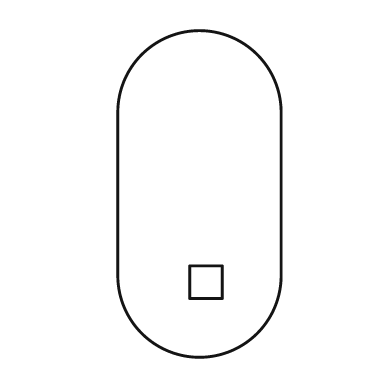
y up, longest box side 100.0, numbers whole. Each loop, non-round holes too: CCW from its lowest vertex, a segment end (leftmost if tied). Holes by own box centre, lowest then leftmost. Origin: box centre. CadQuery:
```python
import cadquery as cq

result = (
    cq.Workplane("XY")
    .moveTo(-25.0, -25.0)
    .threePointArc((0.0, -50.0), (25.0, -25.0))
    .lineTo(25.0, 25.0)
    .threePointArc((0.0, 50.0), (-25.0, 25.0))
    .close()
    .moveTo(-3.0, -32.0)
    .lineTo(7.0, -32.0)
    .lineTo(7.0, -22.0)
    .lineTo(-3.0, -22.0)
    .close()
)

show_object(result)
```